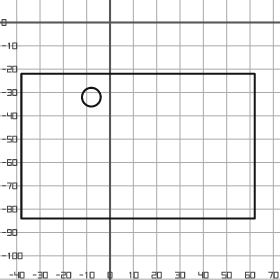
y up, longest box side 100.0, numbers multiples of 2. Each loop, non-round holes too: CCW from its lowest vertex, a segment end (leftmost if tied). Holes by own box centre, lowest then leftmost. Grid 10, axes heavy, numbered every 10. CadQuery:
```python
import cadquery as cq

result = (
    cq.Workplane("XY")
    .moveTo(-38.0, -84.0)
    .lineTo(62.0, -84.0)
    .lineTo(62.0, -22.0)
    .lineTo(-38.0, -22.0)
    .close()
    .moveTo(-8.0, -32.0)
    .circle(4.0)
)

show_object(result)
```